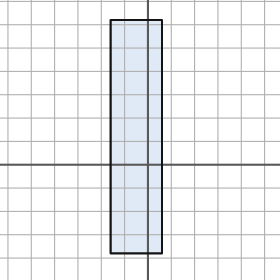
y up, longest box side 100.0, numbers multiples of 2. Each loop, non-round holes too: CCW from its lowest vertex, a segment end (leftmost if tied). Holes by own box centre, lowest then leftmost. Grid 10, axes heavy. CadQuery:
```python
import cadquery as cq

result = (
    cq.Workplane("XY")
    .moveTo(-16.0, -38.0)
    .lineTo(6.0, -38.0)
    .lineTo(6.0, 62.0)
    .lineTo(-16.0, 62.0)
    .close()
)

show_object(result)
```